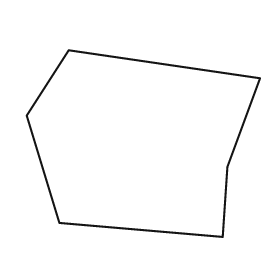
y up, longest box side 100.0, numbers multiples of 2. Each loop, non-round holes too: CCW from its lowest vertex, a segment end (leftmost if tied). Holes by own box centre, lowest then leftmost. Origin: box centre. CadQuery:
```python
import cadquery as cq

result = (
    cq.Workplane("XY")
    .moveTo(34.0, -40.0)
    .lineTo(36.0, -10.0)
    .lineTo(50.0, 28.0)
    .lineTo(-32.0, 40.0)
    .lineTo(-50.0, 12.0)
    .lineTo(-36.0, -34.0)
    .close()
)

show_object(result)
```